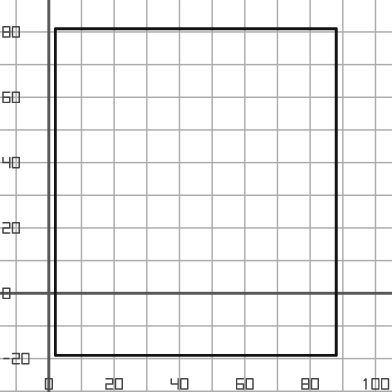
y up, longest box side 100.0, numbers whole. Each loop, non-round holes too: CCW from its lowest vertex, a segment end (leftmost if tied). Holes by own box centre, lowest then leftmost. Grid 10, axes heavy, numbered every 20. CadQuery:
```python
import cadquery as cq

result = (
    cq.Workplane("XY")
    .moveTo(2.0, -19.0)
    .lineTo(88.0, -19.0)
    .lineTo(88.0, 81.0)
    .lineTo(2.0, 81.0)
    .close()
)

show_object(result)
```